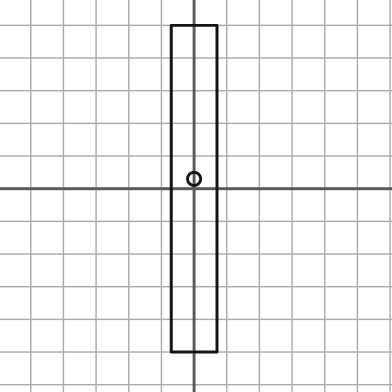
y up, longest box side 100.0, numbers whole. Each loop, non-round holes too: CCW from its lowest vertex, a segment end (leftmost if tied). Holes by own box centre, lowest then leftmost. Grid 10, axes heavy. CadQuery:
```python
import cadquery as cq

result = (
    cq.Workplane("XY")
    .moveTo(-7.0, -50.0)
    .lineTo(7.0, -50.0)
    .lineTo(7.0, 50.0)
    .lineTo(-7.0, 50.0)
    .close()
    .moveTo(0.0, 3.0)
    .circle(2.0)
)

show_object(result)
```